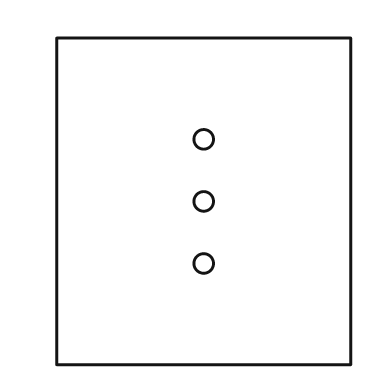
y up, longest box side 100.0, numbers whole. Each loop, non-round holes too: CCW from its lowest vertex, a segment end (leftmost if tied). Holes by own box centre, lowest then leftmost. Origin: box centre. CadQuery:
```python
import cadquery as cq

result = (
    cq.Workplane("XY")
    .moveTo(-45.0, -50.0)
    .lineTo(45.0, -50.0)
    .lineTo(45.0, 50.0)
    .lineTo(-45.0, 50.0)
    .close()
    .moveTo(0.0, -19.0)
    .circle(3.0)
    .moveTo(0.0, 0.0)
    .circle(3.0)
    .moveTo(0.0, 19.0)
    .circle(3.0)
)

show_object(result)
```